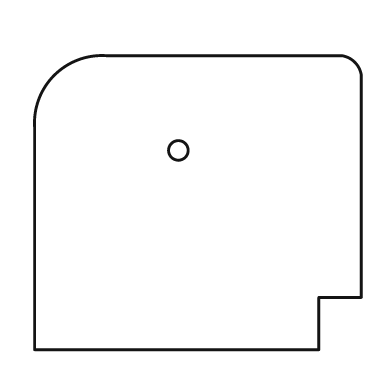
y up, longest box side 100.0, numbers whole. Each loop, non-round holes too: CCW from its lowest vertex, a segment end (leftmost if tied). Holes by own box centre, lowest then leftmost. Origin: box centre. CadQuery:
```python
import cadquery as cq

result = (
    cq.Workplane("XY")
    .moveTo(-50.0, -45.0)
    .lineTo(37.0, -45.0)
    .lineTo(37.0, -29.0)
    .lineTo(50.0, -29.0)
    .lineTo(50.0, 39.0)
    .threePointArc((48.0, 43.0), (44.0, 45.0))
    .lineTo(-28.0, 45.0)
    .threePointArc((-44.0, 39.0), (-50.0, 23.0))
    .close()
    .moveTo(-6.0, 16.0)
    .circle(3.0)
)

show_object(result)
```